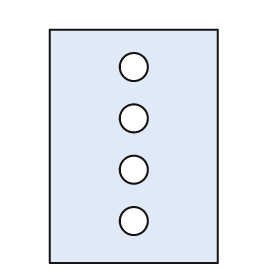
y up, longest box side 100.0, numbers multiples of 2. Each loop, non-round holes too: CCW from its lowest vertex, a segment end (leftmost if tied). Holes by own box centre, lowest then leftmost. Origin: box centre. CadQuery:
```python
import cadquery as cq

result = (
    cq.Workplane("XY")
    .moveTo(-36.0, -50.0)
    .lineTo(36.0, -50.0)
    .lineTo(36.0, 50.0)
    .lineTo(-36.0, 50.0)
    .close()
    .moveTo(0.0, -32.0)
    .circle(6.0)
    .moveTo(0.0, -10.0)
    .circle(6.0)
    .moveTo(0.0, 12.0)
    .circle(6.0)
    .moveTo(0.0, 34.0)
    .circle(6.0)
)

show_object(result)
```